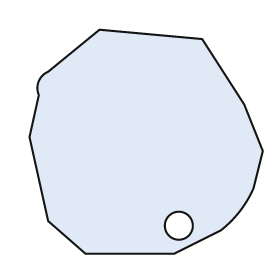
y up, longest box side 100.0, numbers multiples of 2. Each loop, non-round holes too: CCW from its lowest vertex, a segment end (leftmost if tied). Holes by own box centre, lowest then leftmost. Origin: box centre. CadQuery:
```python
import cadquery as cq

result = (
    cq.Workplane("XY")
    .moveTo(-26.0, -48.0)
    .lineTo(12.0, -48.0)
    .lineTo(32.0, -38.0)
    .threePointArc((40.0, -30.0), (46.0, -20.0))
    .lineTo(50.0, -4.0)
    .lineTo(42.0, 16.0)
    .lineTo(24.0, 44.0)
    .lineTo(-20.0, 48.0)
    .lineTo(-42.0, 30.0)
    .threePointArc((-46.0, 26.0), (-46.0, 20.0))
    .lineTo(-50.0, 2.0)
    .lineTo(-42.0, -34.0)
    .close()
    .moveTo(14.0, -36.0)
    .circle(6.0)
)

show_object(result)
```